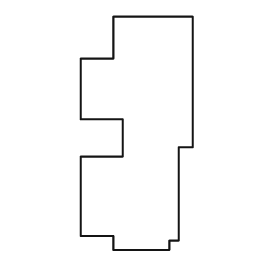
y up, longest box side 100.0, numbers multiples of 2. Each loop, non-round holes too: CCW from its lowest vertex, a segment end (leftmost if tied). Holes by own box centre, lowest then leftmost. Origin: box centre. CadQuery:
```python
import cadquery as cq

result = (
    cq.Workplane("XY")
    .moveTo(-10.0, -50.0)
    .lineTo(14.0, -50.0)
    .lineTo(14.0, -46.0)
    .lineTo(18.0, -46.0)
    .lineTo(18.0, -6.0)
    .lineTo(24.0, -6.0)
    .lineTo(24.0, 50.0)
    .lineTo(-10.0, 50.0)
    .lineTo(-10.0, 32.0)
    .lineTo(-24.0, 32.0)
    .lineTo(-24.0, 6.0)
    .lineTo(-6.0, 6.0)
    .lineTo(-6.0, -10.0)
    .lineTo(-24.0, -10.0)
    .lineTo(-24.0, -44.0)
    .lineTo(-10.0, -44.0)
    .close()
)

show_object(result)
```